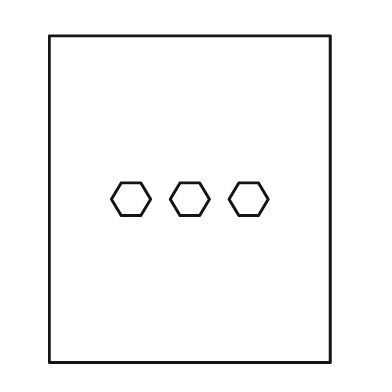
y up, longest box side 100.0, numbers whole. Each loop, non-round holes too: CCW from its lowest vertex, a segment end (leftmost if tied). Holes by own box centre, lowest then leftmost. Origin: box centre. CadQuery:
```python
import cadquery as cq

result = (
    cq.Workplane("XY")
    .moveTo(-43.0, -50.0)
    .lineTo(43.0, -50.0)
    .lineTo(43.0, 50.0)
    .lineTo(-43.0, 50.0)
    .close()
    .moveTo(-21.0, -5.0)
    .lineTo(-15.0, -5.0)
    .lineTo(-12.0, 0.0)
    .lineTo(-15.0, 5.0)
    .lineTo(-21.0, 5.0)
    .lineTo(-24.0, 0.0)
    .close()
    .moveTo(-3.0, -5.0)
    .lineTo(3.0, -5.0)
    .lineTo(6.0, 0.0)
    .lineTo(3.0, 5.0)
    .lineTo(-3.0, 5.0)
    .lineTo(-6.0, 0.0)
    .close()
    .moveTo(15.0, -5.0)
    .lineTo(21.0, -5.0)
    .lineTo(24.0, 0.0)
    .lineTo(21.0, 5.0)
    .lineTo(15.0, 5.0)
    .lineTo(12.0, 0.0)
    .close()
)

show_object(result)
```